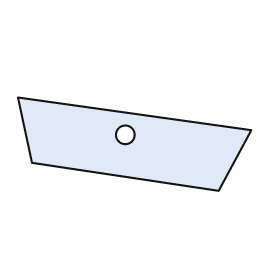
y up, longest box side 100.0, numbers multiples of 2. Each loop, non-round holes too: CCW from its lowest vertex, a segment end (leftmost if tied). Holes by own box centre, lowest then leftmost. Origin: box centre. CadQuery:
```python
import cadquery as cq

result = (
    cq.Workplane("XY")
    .moveTo(36.0, -20.0)
    .lineTo(50.0, 6.0)
    .lineTo(-50.0, 20.0)
    .lineTo(-44.0, -8.0)
    .close()
    .moveTo(-4.0, 4.0)
    .circle(4.0)
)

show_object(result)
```